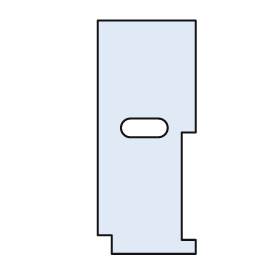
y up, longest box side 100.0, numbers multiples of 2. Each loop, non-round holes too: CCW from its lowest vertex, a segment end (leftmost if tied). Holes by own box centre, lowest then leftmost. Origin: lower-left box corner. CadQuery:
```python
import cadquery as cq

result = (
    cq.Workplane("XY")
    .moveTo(6.0, 0.0)
    .lineTo(42.0, 0.0)
    .lineTo(42.0, 6.0)
    .lineTo(36.0, 6.0)
    .lineTo(36.0, 52.0)
    .lineTo(42.0, 52.0)
    .lineTo(42.0, 100.0)
    .lineTo(0.0, 100.0)
    .lineTo(0.0, 8.0)
    .lineTo(6.0, 8.0)
    .close()
    .moveTo(14.0, 50.0)
    .lineTo(26.0, 50.0)
    .threePointArc((30.0, 54.0), (26.0, 58.0))
    .lineTo(14.0, 58.0)
    .threePointArc((10.0, 54.0), (14.0, 50.0))
    .close()
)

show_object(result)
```